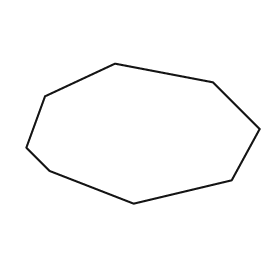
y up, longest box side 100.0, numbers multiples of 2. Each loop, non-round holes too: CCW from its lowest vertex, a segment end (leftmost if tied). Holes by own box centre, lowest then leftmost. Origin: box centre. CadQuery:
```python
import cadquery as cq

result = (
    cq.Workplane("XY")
    .moveTo(-4.0, -30.0)
    .lineTo(38.0, -20.0)
    .lineTo(50.0, 2.0)
    .lineTo(30.0, 22.0)
    .lineTo(-12.0, 30.0)
    .lineTo(-42.0, 16.0)
    .lineTo(-50.0, -6.0)
    .lineTo(-40.0, -16.0)
    .close()
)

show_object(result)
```